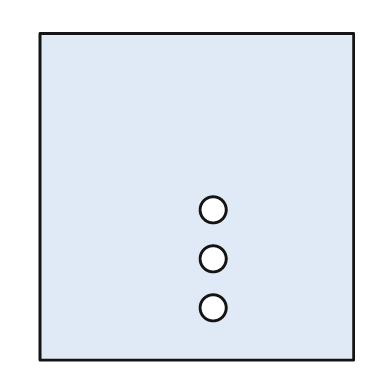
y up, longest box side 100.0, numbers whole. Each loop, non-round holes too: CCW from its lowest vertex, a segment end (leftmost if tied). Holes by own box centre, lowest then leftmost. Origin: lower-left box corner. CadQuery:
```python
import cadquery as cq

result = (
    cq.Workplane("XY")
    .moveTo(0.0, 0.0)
    .lineTo(96.0, 0.0)
    .lineTo(96.0, 100.0)
    .lineTo(0.0, 100.0)
    .close()
    .moveTo(53.0, 16.0)
    .circle(4.0)
    .moveTo(53.0, 31.0)
    .circle(4.0)
    .moveTo(53.0, 46.0)
    .circle(4.0)
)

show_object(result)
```